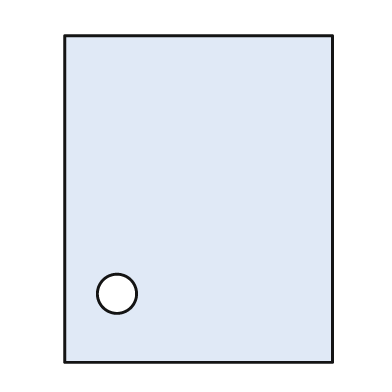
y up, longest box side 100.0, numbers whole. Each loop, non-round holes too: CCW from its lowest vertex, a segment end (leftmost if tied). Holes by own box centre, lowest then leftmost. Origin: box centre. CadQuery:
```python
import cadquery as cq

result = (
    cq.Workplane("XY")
    .moveTo(-41.0, -50.0)
    .lineTo(41.0, -50.0)
    .lineTo(41.0, 50.0)
    .lineTo(-41.0, 50.0)
    .close()
    .moveTo(-25.0, -29.0)
    .circle(6.0)
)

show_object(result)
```